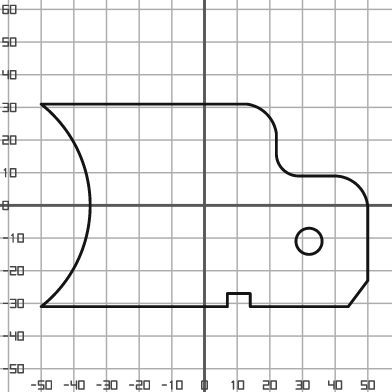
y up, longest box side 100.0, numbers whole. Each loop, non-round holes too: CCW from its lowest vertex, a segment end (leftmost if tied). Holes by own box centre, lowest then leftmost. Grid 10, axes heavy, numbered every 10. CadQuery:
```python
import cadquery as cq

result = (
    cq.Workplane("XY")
    .moveTo(-50.0, -31.0)
    .lineTo(7.0, -31.0)
    .lineTo(7.0, -27.0)
    .lineTo(14.0, -27.0)
    .lineTo(14.0, -31.0)
    .lineTo(44.0, -31.0)
    .lineTo(50.0, -23.0)
    .lineTo(50.0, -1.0)
    .threePointArc((47.0, 6.0), (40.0, 9.0))
    .lineTo(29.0, 9.0)
    .threePointArc((24.0, 11.0), (22.0, 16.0))
    .lineTo(22.0, 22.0)
    .threePointArc((19.0, 28.0), (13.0, 31.0))
    .lineTo(-50.0, 31.0)
    .threePointArc((-35.0, 0.0), (-50.0, -31.0))
    .close()
    .moveTo(32.0, -11.0)
    .circle(4.0)
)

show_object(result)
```